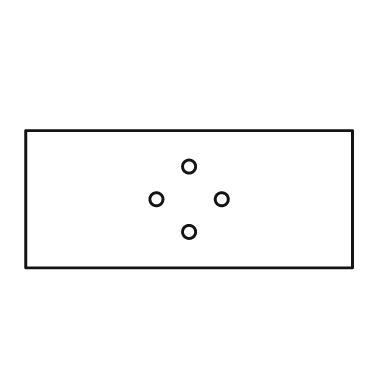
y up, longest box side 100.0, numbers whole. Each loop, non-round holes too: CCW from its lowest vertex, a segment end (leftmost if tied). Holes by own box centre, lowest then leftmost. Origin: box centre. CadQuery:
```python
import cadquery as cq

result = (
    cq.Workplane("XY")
    .moveTo(-50.0, -21.0)
    .lineTo(50.0, -21.0)
    .lineTo(50.0, 21.0)
    .lineTo(-50.0, 21.0)
    .close()
    .moveTo(0.0, -10.0)
    .circle(2.0)
    .moveTo(-10.0, 0.0)
    .circle(2.0)
    .moveTo(10.0, 0.0)
    .circle(2.0)
    .moveTo(0.0, 10.0)
    .circle(2.0)
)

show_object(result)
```